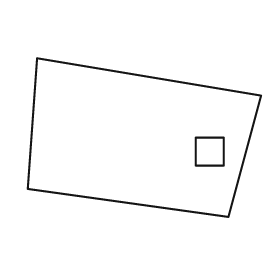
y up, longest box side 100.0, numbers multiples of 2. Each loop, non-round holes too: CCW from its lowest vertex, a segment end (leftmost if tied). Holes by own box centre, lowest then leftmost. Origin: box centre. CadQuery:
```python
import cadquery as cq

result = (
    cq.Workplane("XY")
    .moveTo(36.0, -34.0)
    .lineTo(50.0, 18.0)
    .lineTo(-46.0, 34.0)
    .lineTo(-50.0, -22.0)
    .close()
    .moveTo(22.0, -12.0)
    .lineTo(34.0, -12.0)
    .lineTo(34.0, 0.0)
    .lineTo(22.0, 0.0)
    .close()
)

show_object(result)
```